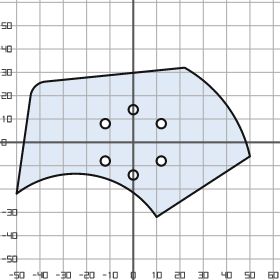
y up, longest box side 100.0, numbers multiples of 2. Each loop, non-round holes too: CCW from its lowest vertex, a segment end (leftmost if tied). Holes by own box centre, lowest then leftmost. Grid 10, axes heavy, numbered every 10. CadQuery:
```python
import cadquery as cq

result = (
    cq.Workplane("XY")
    .moveTo(10.0, -32.0)
    .lineTo(50.0, -6.0)
    .threePointArc((40.0, 16.0), (22.0, 32.0))
    .lineTo(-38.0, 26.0)
    .threePointArc((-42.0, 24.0), (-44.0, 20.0))
    .lineTo(-50.0, -22.0)
    .threePointArc((-18.0, -14.0), (10.0, -32.0))
    .close()
    .moveTo(0.0, -14.0)
    .circle(2.0)
    .moveTo(-12.0, -8.0)
    .circle(2.0)
    .moveTo(12.0, -8.0)
    .circle(2.0)
    .moveTo(-12.0, 8.0)
    .circle(2.0)
    .moveTo(12.0, 8.0)
    .circle(2.0)
    .moveTo(0.0, 14.0)
    .circle(2.0)
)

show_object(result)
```